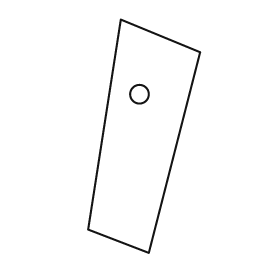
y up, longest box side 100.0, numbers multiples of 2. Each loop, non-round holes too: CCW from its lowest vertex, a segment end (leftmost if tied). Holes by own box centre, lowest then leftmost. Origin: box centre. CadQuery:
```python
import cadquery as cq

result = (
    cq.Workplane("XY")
    .moveTo(2.0, -50.0)
    .lineTo(24.0, 36.0)
    .lineTo(-10.0, 50.0)
    .lineTo(-24.0, -40.0)
    .close()
    .moveTo(-2.0, 18.0)
    .circle(4.0)
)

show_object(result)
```